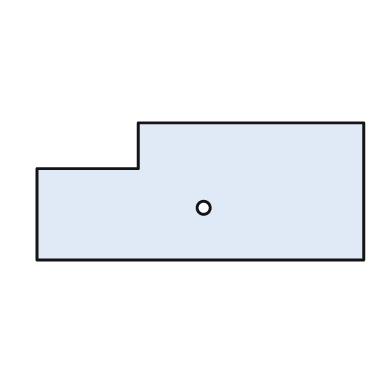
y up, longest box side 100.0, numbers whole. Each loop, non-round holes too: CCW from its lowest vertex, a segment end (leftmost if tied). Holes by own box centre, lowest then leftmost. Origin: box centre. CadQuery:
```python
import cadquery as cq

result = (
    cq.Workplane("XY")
    .moveTo(-50.0, -21.0)
    .lineTo(50.0, -21.0)
    .lineTo(50.0, 21.0)
    .lineTo(-19.0, 21.0)
    .lineTo(-19.0, 7.0)
    .lineTo(-50.0, 7.0)
    .close()
    .moveTo(1.0, -5.0)
    .circle(2.0)
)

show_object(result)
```